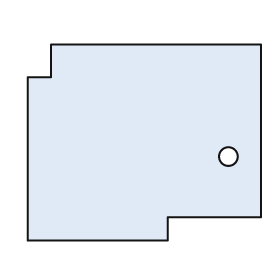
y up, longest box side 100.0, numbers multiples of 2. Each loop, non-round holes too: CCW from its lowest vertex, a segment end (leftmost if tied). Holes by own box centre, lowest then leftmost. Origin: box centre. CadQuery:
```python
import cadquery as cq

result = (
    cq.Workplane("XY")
    .moveTo(-50.0, -42.0)
    .lineTo(10.0, -42.0)
    .lineTo(10.0, -32.0)
    .lineTo(50.0, -32.0)
    .lineTo(50.0, 42.0)
    .lineTo(-40.0, 42.0)
    .lineTo(-40.0, 28.0)
    .lineTo(-50.0, 28.0)
    .close()
    .moveTo(36.0, -6.0)
    .circle(4.0)
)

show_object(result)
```